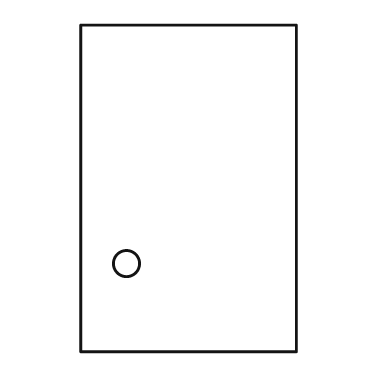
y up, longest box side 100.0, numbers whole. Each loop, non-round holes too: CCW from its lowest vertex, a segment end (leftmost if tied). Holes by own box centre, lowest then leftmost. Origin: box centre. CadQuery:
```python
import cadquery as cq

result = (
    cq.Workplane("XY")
    .moveTo(-33.0, -50.0)
    .lineTo(33.0, -50.0)
    .lineTo(33.0, 50.0)
    .lineTo(-33.0, 50.0)
    .close()
    .moveTo(-19.0, -23.0)
    .circle(4.0)
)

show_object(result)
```